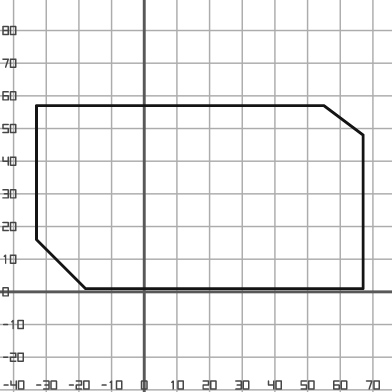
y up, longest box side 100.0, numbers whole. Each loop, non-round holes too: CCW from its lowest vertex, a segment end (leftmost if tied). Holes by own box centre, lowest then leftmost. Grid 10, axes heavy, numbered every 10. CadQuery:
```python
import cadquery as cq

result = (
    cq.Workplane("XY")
    .moveTo(-18.0, 1.0)
    .lineTo(67.0, 1.0)
    .lineTo(67.0, 48.0)
    .lineTo(55.0, 57.0)
    .lineTo(-33.0, 57.0)
    .lineTo(-33.0, 16.0)
    .close()
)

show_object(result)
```